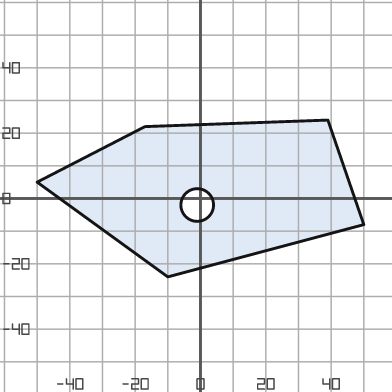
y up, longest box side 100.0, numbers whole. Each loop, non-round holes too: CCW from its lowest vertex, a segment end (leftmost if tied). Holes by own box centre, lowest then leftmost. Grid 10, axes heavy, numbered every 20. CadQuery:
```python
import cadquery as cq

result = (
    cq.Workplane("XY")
    .moveTo(-10.0, -24.0)
    .lineTo(50.0, -8.0)
    .lineTo(39.0, 24.0)
    .lineTo(-17.0, 22.0)
    .lineTo(-50.0, 5.0)
    .close()
    .moveTo(-1.0, -2.0)
    .circle(5.0)
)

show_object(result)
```